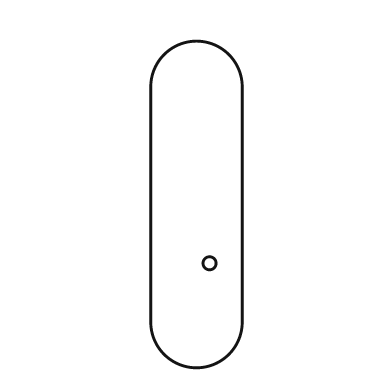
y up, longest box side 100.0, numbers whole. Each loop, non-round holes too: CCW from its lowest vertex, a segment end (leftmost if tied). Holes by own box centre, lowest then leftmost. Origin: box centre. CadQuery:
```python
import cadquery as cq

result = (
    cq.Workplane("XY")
    .moveTo(-14.0, -36.0)
    .threePointArc((0.0, -50.0), (14.0, -36.0))
    .lineTo(14.0, 36.0)
    .threePointArc((0.0, 50.0), (-14.0, 36.0))
    .close()
    .moveTo(4.0, -18.0)
    .circle(2.0)
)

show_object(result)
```